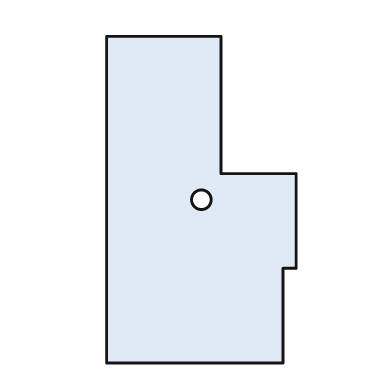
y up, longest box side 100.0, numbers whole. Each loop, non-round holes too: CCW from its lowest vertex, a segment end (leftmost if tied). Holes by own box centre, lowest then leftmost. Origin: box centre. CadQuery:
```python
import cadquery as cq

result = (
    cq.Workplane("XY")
    .moveTo(-29.0, -50.0)
    .lineTo(25.0, -50.0)
    .lineTo(25.0, -21.0)
    .lineTo(29.0, -21.0)
    .lineTo(29.0, 8.0)
    .lineTo(6.0, 8.0)
    .lineTo(6.0, 50.0)
    .lineTo(-29.0, 50.0)
    .close()
    .moveTo(0.0, 0.0)
    .circle(3.0)
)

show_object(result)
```